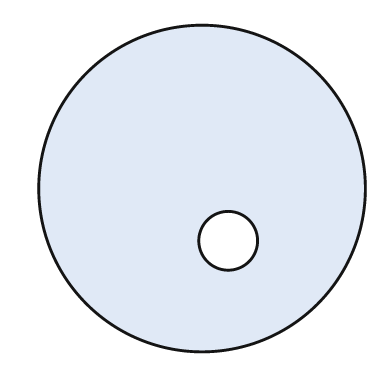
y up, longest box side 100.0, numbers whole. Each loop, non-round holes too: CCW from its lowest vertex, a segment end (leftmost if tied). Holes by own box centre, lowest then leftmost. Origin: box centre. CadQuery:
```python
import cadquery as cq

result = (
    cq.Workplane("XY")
    .moveTo(0.0, 0.0)
    .circle(50.0)
    .moveTo(8.0, -16.0)
    .circle(9.0)
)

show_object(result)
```